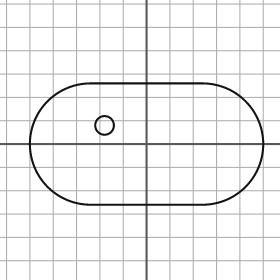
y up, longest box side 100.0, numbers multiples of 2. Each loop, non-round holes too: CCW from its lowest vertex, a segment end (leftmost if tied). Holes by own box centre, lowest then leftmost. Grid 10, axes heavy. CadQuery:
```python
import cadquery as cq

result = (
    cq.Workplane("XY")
    .moveTo(-24.0, -26.0)
    .lineTo(24.0, -26.0)
    .threePointArc((50.0, 0.0), (24.0, 26.0))
    .lineTo(-24.0, 26.0)
    .threePointArc((-50.0, 0.0), (-24.0, -26.0))
    .close()
    .moveTo(-18.0, 8.0)
    .circle(4.0)
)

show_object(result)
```